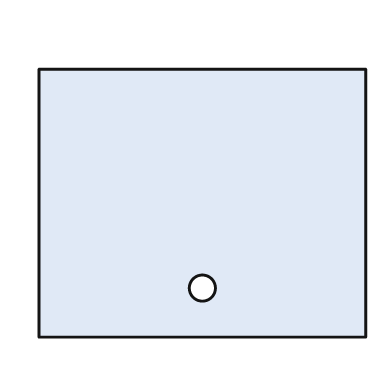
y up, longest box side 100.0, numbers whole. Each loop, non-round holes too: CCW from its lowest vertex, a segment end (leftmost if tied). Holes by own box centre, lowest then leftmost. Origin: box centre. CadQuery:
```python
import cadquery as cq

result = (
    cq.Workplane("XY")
    .moveTo(-50.0, -41.0)
    .lineTo(50.0, -41.0)
    .lineTo(50.0, 41.0)
    .lineTo(-50.0, 41.0)
    .close()
    .moveTo(0.0, -26.0)
    .circle(4.0)
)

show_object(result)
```